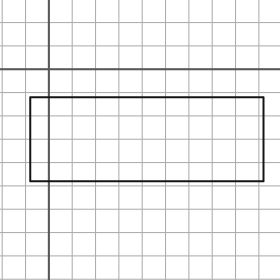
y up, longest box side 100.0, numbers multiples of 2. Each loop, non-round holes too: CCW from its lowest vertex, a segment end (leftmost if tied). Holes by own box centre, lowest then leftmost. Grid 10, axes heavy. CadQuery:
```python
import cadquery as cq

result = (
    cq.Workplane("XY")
    .moveTo(-8.0, -48.0)
    .lineTo(92.0, -48.0)
    .lineTo(92.0, -12.0)
    .lineTo(-8.0, -12.0)
    .close()
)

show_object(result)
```